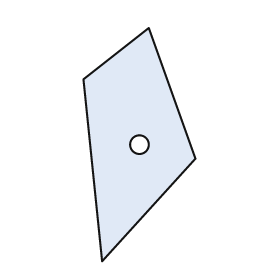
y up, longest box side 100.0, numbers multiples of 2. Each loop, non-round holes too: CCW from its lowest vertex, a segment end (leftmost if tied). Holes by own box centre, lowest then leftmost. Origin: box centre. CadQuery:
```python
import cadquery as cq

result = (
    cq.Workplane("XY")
    .moveTo(-16.0, -50.0)
    .lineTo(24.0, -6.0)
    .lineTo(4.0, 50.0)
    .lineTo(-24.0, 28.0)
    .close()
    .moveTo(0.0, 0.0)
    .circle(4.0)
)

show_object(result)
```